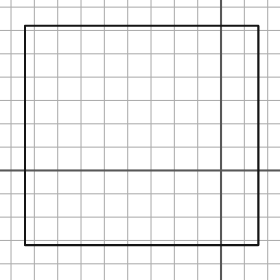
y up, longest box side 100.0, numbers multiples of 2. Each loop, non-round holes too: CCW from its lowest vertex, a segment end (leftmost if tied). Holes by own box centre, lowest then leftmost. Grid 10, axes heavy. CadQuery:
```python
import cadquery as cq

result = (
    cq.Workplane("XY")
    .moveTo(-84.0, -32.0)
    .lineTo(16.0, -32.0)
    .lineTo(16.0, 62.0)
    .lineTo(-84.0, 62.0)
    .close()
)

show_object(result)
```